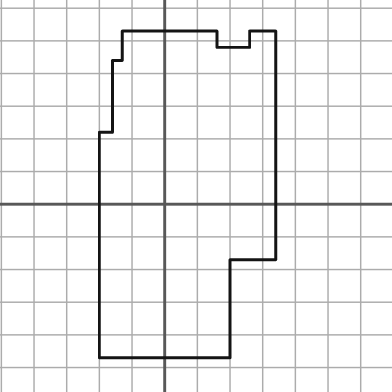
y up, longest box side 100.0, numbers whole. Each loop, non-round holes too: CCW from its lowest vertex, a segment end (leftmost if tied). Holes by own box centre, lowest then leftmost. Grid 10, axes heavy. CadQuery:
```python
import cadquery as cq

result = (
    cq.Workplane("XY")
    .moveTo(-20.0, -47.0)
    .lineTo(20.0, -47.0)
    .lineTo(20.0, -17.0)
    .lineTo(34.0, -17.0)
    .lineTo(34.0, 53.0)
    .lineTo(26.0, 53.0)
    .lineTo(26.0, 48.0)
    .lineTo(16.0, 48.0)
    .lineTo(16.0, 53.0)
    .lineTo(-13.0, 53.0)
    .lineTo(-13.0, 44.0)
    .lineTo(-16.0, 44.0)
    .lineTo(-16.0, 22.0)
    .lineTo(-20.0, 22.0)
    .close()
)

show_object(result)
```